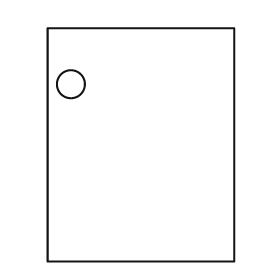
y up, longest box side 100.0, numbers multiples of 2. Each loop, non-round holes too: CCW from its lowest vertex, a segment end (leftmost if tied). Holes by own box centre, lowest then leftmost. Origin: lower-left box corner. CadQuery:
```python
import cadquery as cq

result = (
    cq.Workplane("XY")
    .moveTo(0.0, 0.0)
    .lineTo(80.0, 0.0)
    .lineTo(80.0, 100.0)
    .lineTo(0.0, 100.0)
    .close()
    .moveTo(10.0, 76.0)
    .circle(6.0)
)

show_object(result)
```